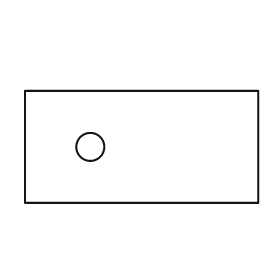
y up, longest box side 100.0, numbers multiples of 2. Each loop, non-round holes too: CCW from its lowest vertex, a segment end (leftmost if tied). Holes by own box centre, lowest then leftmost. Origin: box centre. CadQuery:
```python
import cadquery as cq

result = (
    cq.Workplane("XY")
    .moveTo(-50.0, -24.0)
    .lineTo(50.0, -24.0)
    .lineTo(50.0, 24.0)
    .lineTo(-50.0, 24.0)
    .close()
    .moveTo(-22.0, 0.0)
    .circle(6.0)
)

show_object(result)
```